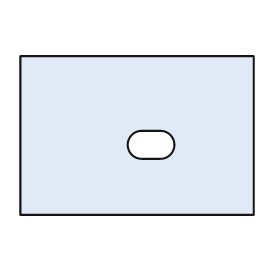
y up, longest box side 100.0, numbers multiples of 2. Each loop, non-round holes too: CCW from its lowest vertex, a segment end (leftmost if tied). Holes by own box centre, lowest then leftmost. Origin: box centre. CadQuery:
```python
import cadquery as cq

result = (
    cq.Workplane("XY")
    .moveTo(-50.0, -34.0)
    .lineTo(50.0, -34.0)
    .lineTo(50.0, 34.0)
    .lineTo(-50.0, 34.0)
    .close()
    .moveTo(2.0, -10.0)
    .lineTo(10.0, -10.0)
    .threePointArc((16.0, -4.0), (10.0, 2.0))
    .lineTo(2.0, 2.0)
    .threePointArc((-4.0, -4.0), (2.0, -10.0))
    .close()
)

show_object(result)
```